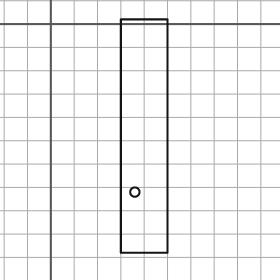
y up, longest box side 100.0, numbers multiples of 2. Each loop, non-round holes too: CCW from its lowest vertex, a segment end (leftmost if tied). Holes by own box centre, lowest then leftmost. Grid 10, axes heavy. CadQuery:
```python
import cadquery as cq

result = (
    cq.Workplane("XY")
    .moveTo(30.0, -98.0)
    .lineTo(50.0, -98.0)
    .lineTo(50.0, 2.0)
    .lineTo(30.0, 2.0)
    .close()
    .moveTo(36.0, -72.0)
    .circle(2.0)
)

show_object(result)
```